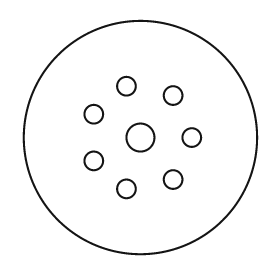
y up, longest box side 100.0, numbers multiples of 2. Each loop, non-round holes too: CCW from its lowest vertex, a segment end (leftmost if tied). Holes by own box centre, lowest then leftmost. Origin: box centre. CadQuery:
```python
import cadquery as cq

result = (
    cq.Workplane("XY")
    .moveTo(0.0, 0.0)
    .circle(50.0)
    .moveTo(-6.0, -22.0)
    .circle(4.0)
    .moveTo(14.0, -18.0)
    .circle(4.0)
    .moveTo(-20.0, -10.0)
    .circle(4.0)
    .moveTo(0.0, 0.0)
    .circle(6.0)
    .moveTo(22.0, 0.0)
    .circle(4.0)
    .moveTo(-20.0, 10.0)
    .circle(4.0)
    .moveTo(14.0, 18.0)
    .circle(4.0)
    .moveTo(-6.0, 22.0)
    .circle(4.0)
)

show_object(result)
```